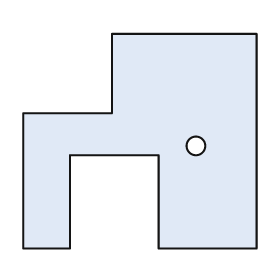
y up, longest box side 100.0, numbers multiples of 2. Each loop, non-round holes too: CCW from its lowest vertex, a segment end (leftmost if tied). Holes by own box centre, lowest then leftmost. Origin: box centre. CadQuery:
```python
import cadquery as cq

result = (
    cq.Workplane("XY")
    .moveTo(-50.0, -46.0)
    .lineTo(-30.0, -46.0)
    .lineTo(-30.0, -6.0)
    .lineTo(8.0, -6.0)
    .lineTo(8.0, -46.0)
    .lineTo(50.0, -46.0)
    .lineTo(50.0, 46.0)
    .lineTo(-12.0, 46.0)
    .lineTo(-12.0, 12.0)
    .lineTo(-50.0, 12.0)
    .close()
    .moveTo(24.0, -2.0)
    .circle(4.0)
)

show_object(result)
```